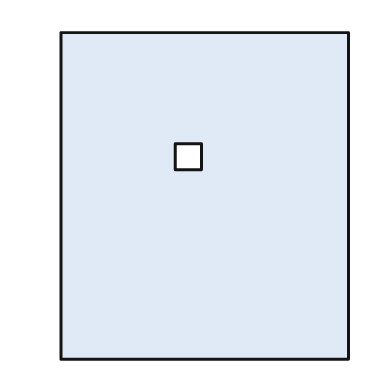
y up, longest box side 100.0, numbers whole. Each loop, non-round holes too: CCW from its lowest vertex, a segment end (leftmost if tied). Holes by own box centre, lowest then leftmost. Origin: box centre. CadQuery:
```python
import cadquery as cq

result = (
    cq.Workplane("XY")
    .moveTo(-44.0, -50.0)
    .lineTo(44.0, -50.0)
    .lineTo(44.0, 50.0)
    .lineTo(-44.0, 50.0)
    .close()
    .moveTo(-9.0, 8.0)
    .lineTo(-1.0, 8.0)
    .lineTo(-1.0, 16.0)
    .lineTo(-9.0, 16.0)
    .close()
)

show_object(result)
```